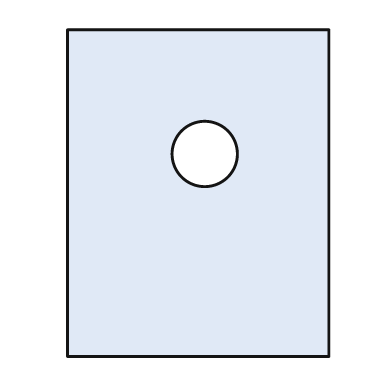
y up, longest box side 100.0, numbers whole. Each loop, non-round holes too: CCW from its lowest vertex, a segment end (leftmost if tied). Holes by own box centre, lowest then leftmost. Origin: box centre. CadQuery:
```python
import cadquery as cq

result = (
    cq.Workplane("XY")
    .moveTo(-40.0, -50.0)
    .lineTo(40.0, -50.0)
    .lineTo(40.0, 50.0)
    .lineTo(-40.0, 50.0)
    .close()
    .moveTo(2.0, 12.0)
    .circle(10.0)
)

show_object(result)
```